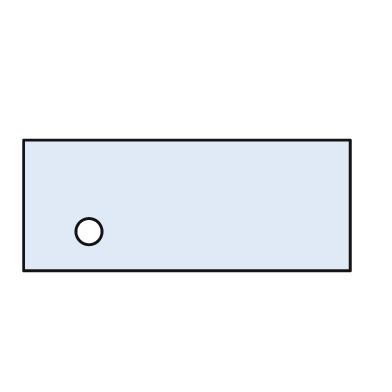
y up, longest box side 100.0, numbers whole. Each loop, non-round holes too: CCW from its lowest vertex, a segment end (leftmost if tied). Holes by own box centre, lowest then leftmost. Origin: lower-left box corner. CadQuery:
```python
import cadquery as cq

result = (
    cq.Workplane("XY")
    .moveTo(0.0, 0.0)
    .lineTo(100.0, 0.0)
    .lineTo(100.0, 40.0)
    .lineTo(0.0, 40.0)
    .close()
    .moveTo(20.0, 12.0)
    .circle(4.0)
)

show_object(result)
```